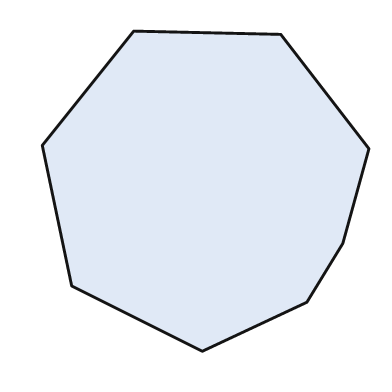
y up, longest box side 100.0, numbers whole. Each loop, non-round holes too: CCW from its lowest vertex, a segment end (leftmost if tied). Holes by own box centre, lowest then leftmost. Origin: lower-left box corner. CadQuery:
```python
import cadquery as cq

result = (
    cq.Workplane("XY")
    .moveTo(49.0, 0.0)
    .lineTo(81.0, 15.0)
    .lineTo(92.0, 33.0)
    .lineTo(100.0, 62.0)
    .lineTo(73.0, 97.0)
    .lineTo(28.0, 98.0)
    .lineTo(0.0, 63.0)
    .lineTo(9.0, 20.0)
    .close()
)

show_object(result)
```